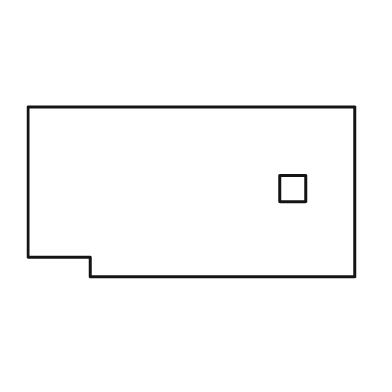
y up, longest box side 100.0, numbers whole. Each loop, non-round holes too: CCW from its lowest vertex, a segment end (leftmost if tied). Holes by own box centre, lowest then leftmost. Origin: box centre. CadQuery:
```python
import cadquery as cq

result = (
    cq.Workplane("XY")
    .moveTo(-31.0, -26.0)
    .lineTo(50.0, -26.0)
    .lineTo(50.0, 26.0)
    .lineTo(-50.0, 26.0)
    .lineTo(-50.0, -20.0)
    .lineTo(-31.0, -20.0)
    .close()
    .moveTo(27.0, -3.0)
    .lineTo(35.0, -3.0)
    .lineTo(35.0, 5.0)
    .lineTo(27.0, 5.0)
    .close()
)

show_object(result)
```